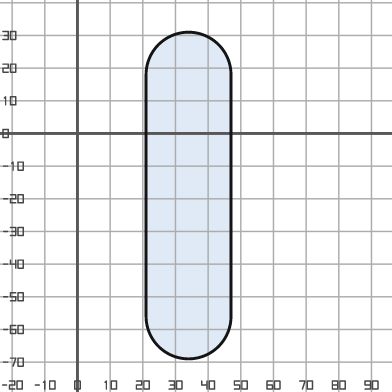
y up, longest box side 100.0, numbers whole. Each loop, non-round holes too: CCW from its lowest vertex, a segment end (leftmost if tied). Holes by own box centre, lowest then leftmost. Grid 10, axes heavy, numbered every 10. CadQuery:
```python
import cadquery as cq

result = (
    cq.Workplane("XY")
    .moveTo(21.0, -56.0)
    .threePointArc((34.0, -69.0), (47.0, -56.0))
    .lineTo(47.0, 18.0)
    .threePointArc((34.0, 31.0), (21.0, 18.0))
    .close()
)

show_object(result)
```